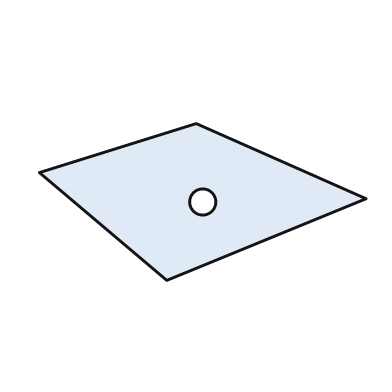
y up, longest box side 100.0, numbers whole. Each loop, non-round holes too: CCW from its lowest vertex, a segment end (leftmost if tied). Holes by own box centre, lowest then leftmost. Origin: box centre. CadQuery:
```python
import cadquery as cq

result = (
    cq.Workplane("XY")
    .moveTo(-11.0, -24.0)
    .lineTo(50.0, 1.0)
    .lineTo(-2.0, 24.0)
    .lineTo(-50.0, 9.0)
    .close()
    .moveTo(0.0, 0.0)
    .circle(4.0)
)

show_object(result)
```